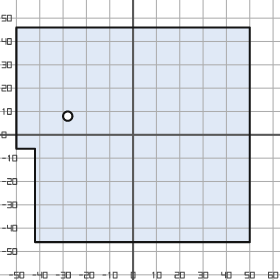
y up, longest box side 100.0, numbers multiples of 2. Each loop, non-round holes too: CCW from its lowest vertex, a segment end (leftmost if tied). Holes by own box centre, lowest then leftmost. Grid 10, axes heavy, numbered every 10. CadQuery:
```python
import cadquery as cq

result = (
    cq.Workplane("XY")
    .moveTo(-42.0, -46.0)
    .lineTo(50.0, -46.0)
    .lineTo(50.0, 46.0)
    .lineTo(-50.0, 46.0)
    .lineTo(-50.0, -6.0)
    .lineTo(-42.0, -6.0)
    .close()
    .moveTo(-28.0, 8.0)
    .circle(2.0)
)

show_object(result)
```